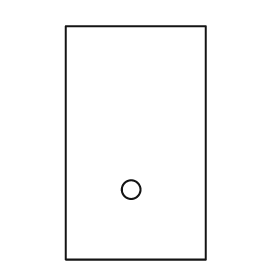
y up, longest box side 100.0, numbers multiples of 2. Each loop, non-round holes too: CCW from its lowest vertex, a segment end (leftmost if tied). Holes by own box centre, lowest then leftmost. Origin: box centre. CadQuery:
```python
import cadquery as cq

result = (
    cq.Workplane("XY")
    .moveTo(-30.0, -50.0)
    .lineTo(30.0, -50.0)
    .lineTo(30.0, 50.0)
    .lineTo(-30.0, 50.0)
    .close()
    .moveTo(-2.0, -20.0)
    .circle(4.0)
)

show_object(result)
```